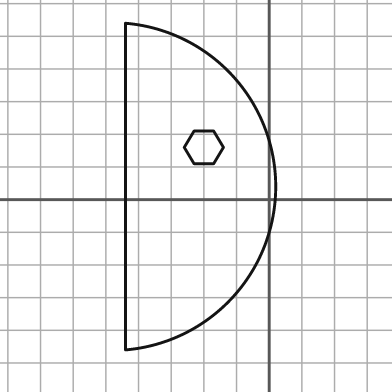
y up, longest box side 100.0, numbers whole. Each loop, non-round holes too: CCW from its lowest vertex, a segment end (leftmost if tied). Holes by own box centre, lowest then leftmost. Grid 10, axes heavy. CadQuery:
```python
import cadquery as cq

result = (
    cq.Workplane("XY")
    .moveTo(-44.0, -46.0)
    .threePointArc((2.0, 4.0), (-44.0, 54.0))
    .close()
    .moveTo(-23.0, 11.0)
    .lineTo(-17.0, 11.0)
    .lineTo(-14.0, 16.0)
    .lineTo(-17.0, 21.0)
    .lineTo(-23.0, 21.0)
    .lineTo(-26.0, 16.0)
    .close()
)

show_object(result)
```